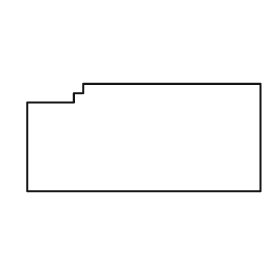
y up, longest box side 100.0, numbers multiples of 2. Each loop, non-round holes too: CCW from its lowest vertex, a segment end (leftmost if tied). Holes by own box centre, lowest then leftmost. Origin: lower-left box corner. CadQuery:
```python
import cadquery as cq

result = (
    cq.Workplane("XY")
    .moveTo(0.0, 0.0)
    .lineTo(100.0, 0.0)
    .lineTo(100.0, 46.0)
    .lineTo(24.0, 46.0)
    .lineTo(24.0, 42.0)
    .lineTo(20.0, 42.0)
    .lineTo(20.0, 38.0)
    .lineTo(0.0, 38.0)
    .close()
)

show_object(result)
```